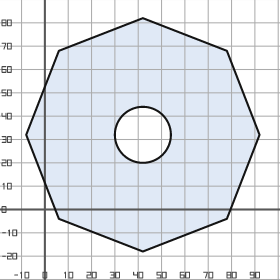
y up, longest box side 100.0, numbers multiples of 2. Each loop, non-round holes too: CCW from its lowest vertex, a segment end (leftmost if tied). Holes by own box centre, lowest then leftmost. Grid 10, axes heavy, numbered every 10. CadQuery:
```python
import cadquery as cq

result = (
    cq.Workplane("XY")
    .moveTo(42.0, -18.0)
    .lineTo(78.0, -4.0)
    .lineTo(92.0, 32.0)
    .lineTo(78.0, 68.0)
    .lineTo(42.0, 82.0)
    .lineTo(6.0, 68.0)
    .lineTo(-8.0, 32.0)
    .lineTo(6.0, -4.0)
    .close()
    .moveTo(42.0, 32.0)
    .circle(12.0)
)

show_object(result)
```